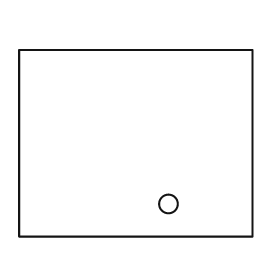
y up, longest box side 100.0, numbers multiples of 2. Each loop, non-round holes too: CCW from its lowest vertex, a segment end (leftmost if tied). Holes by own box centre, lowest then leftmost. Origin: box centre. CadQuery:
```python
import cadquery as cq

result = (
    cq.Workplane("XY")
    .moveTo(-50.0, -40.0)
    .lineTo(50.0, -40.0)
    .lineTo(50.0, 40.0)
    .lineTo(-50.0, 40.0)
    .close()
    .moveTo(14.0, -26.0)
    .circle(4.0)
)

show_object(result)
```